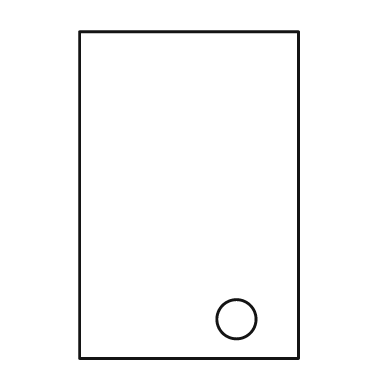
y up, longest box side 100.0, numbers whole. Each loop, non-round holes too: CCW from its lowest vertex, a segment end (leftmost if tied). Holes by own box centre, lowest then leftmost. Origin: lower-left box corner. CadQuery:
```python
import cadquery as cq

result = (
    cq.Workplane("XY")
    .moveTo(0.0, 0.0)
    .lineTo(67.0, 0.0)
    .lineTo(67.0, 100.0)
    .lineTo(0.0, 100.0)
    .close()
    .moveTo(48.0, 12.0)
    .circle(6.0)
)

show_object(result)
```